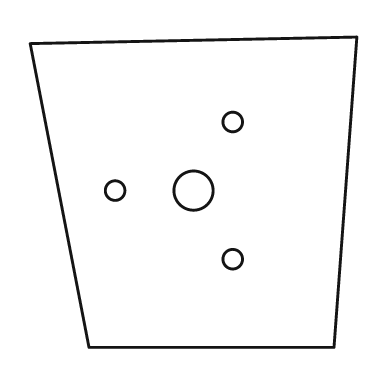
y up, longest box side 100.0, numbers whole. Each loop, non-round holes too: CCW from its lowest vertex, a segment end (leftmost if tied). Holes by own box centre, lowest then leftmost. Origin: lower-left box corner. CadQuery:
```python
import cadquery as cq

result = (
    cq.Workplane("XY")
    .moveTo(18.0, 0.0)
    .lineTo(93.0, 0.0)
    .lineTo(100.0, 95.0)
    .lineTo(0.0, 93.0)
    .close()
    .moveTo(62.0, 27.0)
    .circle(3.0)
    .moveTo(26.0, 48.0)
    .circle(3.0)
    .moveTo(50.0, 48.0)
    .circle(6.0)
    .moveTo(62.0, 69.0)
    .circle(3.0)
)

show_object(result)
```